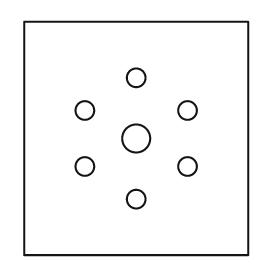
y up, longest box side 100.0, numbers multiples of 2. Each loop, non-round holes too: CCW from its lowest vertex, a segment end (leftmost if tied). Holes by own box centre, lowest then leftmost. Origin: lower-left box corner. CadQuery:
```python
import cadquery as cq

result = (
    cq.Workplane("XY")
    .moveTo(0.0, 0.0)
    .lineTo(96.0, 0.0)
    .lineTo(96.0, 100.0)
    .lineTo(0.0, 100.0)
    .close()
    .moveTo(48.0, 24.0)
    .circle(4.0)
    .moveTo(26.0, 38.0)
    .circle(4.0)
    .moveTo(70.0, 38.0)
    .circle(4.0)
    .moveTo(48.0, 50.0)
    .circle(6.0)
    .moveTo(26.0, 62.0)
    .circle(4.0)
    .moveTo(70.0, 62.0)
    .circle(4.0)
    .moveTo(48.0, 76.0)
    .circle(4.0)
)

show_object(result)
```